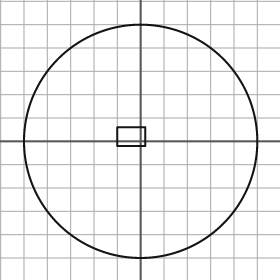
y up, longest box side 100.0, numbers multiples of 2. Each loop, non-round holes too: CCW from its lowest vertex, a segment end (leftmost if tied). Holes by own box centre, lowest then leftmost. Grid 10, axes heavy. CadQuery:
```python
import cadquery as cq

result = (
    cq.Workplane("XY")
    .moveTo(0.0, 0.0)
    .circle(50.0)
    .moveTo(-10.0, -2.0)
    .lineTo(2.0, -2.0)
    .lineTo(2.0, 6.0)
    .lineTo(-10.0, 6.0)
    .close()
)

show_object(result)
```